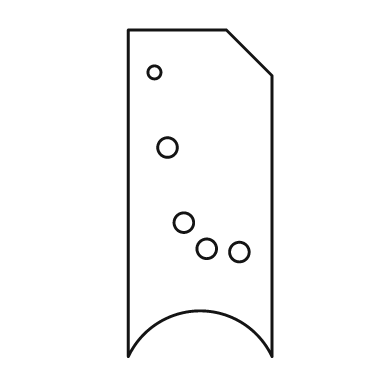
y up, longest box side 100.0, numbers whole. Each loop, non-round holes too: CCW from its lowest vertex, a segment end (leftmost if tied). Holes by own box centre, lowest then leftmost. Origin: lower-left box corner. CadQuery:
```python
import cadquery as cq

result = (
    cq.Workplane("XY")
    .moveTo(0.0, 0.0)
    .threePointArc((22.0, 14.0), (44.0, 0.0))
    .lineTo(44.0, 86.0)
    .lineTo(30.0, 100.0)
    .lineTo(0.0, 100.0)
    .close()
    .moveTo(34.0, 32.0)
    .circle(3.0)
    .moveTo(24.0, 33.0)
    .circle(3.0)
    .moveTo(17.0, 41.0)
    .circle(3.0)
    .moveTo(12.0, 64.0)
    .circle(3.0)
    .moveTo(8.0, 87.0)
    .circle(2.0)
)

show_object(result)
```